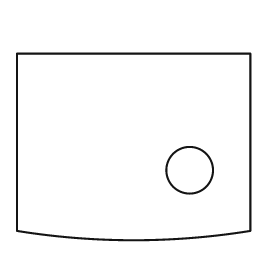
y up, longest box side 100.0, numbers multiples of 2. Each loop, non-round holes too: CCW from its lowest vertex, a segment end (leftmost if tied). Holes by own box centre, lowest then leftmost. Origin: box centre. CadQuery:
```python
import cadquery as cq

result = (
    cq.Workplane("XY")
    .moveTo(-50.0, -36.0)
    .threePointArc((0.0, -40.0), (50.0, -36.0))
    .lineTo(50.0, 40.0)
    .lineTo(-50.0, 40.0)
    .close()
    .moveTo(24.0, -10.0)
    .circle(10.0)
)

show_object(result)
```